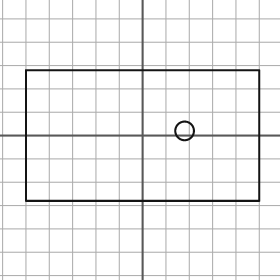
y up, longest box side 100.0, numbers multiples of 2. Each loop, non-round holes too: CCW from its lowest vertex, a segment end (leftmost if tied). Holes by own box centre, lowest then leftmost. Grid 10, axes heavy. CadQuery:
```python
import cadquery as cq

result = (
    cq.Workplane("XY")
    .moveTo(-50.0, -28.0)
    .lineTo(50.0, -28.0)
    .lineTo(50.0, 28.0)
    .lineTo(-50.0, 28.0)
    .close()
    .moveTo(18.0, 2.0)
    .circle(4.0)
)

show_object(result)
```